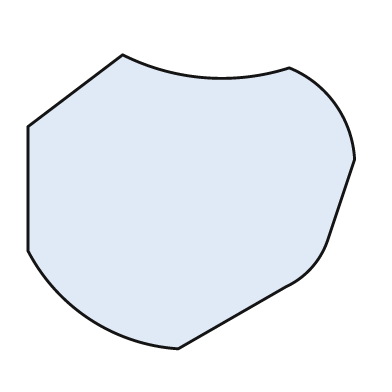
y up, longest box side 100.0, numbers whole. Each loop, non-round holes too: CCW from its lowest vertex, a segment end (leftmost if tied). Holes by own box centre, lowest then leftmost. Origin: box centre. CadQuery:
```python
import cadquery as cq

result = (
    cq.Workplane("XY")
    .moveTo(-4.0, -45.0)
    .lineTo(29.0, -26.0)
    .threePointArc((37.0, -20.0), (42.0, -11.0))
    .lineTo(50.0, 13.0)
    .threePointArc((44.0, 30.0), (30.0, 41.0))
    .threePointArc((4.0, 38.0), (-21.0, 45.0))
    .lineTo(-50.0, 23.0)
    .lineTo(-50.0, -15.0)
    .threePointArc((-31.0, -36.0), (-4.0, -45.0))
    .close()
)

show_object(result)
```